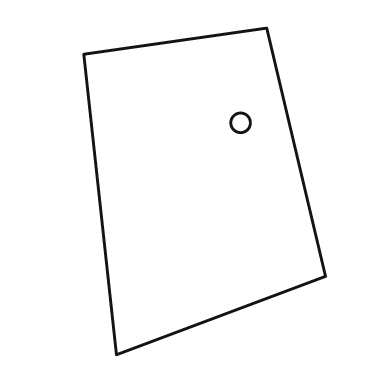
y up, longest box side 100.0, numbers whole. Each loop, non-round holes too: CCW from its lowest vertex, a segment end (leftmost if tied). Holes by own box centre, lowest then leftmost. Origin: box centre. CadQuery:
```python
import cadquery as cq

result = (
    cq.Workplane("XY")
    .moveTo(-27.0, -50.0)
    .lineTo(37.0, -26.0)
    .lineTo(19.0, 50.0)
    .lineTo(-37.0, 42.0)
    .close()
    .moveTo(11.0, 21.0)
    .circle(3.0)
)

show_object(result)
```